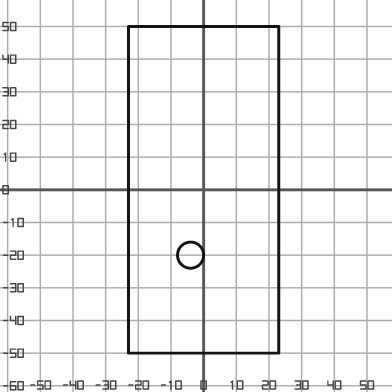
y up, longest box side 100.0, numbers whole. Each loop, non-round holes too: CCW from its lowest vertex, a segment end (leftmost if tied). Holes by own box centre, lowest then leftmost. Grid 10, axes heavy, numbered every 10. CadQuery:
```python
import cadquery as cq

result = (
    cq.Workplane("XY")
    .moveTo(-23.0, -50.0)
    .lineTo(23.0, -50.0)
    .lineTo(23.0, 50.0)
    .lineTo(-23.0, 50.0)
    .close()
    .moveTo(-4.0, -20.0)
    .circle(4.0)
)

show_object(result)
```